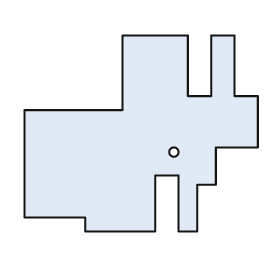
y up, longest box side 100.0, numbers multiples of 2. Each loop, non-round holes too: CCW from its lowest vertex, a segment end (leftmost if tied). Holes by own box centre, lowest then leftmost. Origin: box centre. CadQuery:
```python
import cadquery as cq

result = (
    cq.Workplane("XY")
    .moveTo(-24.0, -42.0)
    .lineTo(6.0, -42.0)
    .lineTo(6.0, -18.0)
    .lineTo(16.0, -18.0)
    .lineTo(16.0, -42.0)
    .lineTo(24.0, -42.0)
    .lineTo(24.0, -22.0)
    .lineTo(32.0, -22.0)
    .lineTo(32.0, -6.0)
    .lineTo(50.0, -6.0)
    .lineTo(50.0, 16.0)
    .lineTo(40.0, 16.0)
    .lineTo(40.0, 42.0)
    .lineTo(30.0, 42.0)
    .lineTo(30.0, 16.0)
    .lineTo(20.0, 16.0)
    .lineTo(20.0, 42.0)
    .lineTo(-8.0, 42.0)
    .lineTo(-8.0, 10.0)
    .lineTo(-50.0, 10.0)
    .lineTo(-50.0, -36.0)
    .lineTo(-24.0, -36.0)
    .close()
    .moveTo(14.0, -8.0)
    .circle(2.0)
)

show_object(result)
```